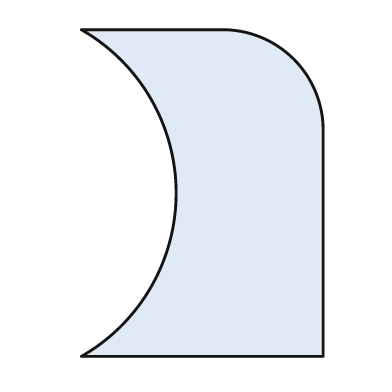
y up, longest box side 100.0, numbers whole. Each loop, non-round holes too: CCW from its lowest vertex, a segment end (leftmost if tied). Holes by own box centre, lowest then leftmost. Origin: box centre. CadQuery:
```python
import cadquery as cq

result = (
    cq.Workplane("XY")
    .moveTo(-37.0, -50.0)
    .lineTo(37.0, -50.0)
    .lineTo(37.0, 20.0)
    .threePointArc((28.0, 41.0), (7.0, 50.0))
    .lineTo(-37.0, 50.0)
    .threePointArc((-8.0, 0.0), (-37.0, -50.0))
    .close()
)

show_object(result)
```